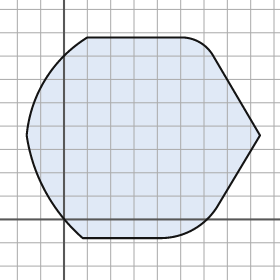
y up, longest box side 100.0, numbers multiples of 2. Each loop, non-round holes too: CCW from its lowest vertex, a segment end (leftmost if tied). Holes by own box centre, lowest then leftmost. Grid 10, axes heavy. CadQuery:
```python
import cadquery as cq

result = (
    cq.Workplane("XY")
    .moveTo(8.0, -8.0)
    .lineTo(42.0, -8.0)
    .threePointArc((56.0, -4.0), (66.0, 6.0))
    .lineTo(84.0, 36.0)
    .lineTo(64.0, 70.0)
    .threePointArc((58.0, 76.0), (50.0, 78.0))
    .lineTo(10.0, 78.0)
    .threePointArc((-8.0, 60.0), (-16.0, 36.0))
    .threePointArc((-8.0, 12.0), (8.0, -8.0))
    .close()
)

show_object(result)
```